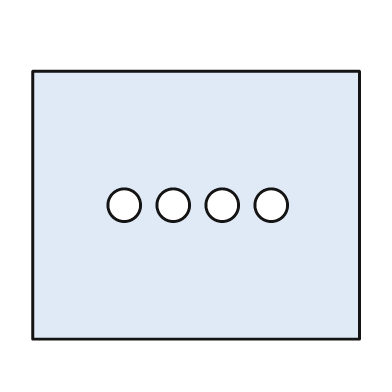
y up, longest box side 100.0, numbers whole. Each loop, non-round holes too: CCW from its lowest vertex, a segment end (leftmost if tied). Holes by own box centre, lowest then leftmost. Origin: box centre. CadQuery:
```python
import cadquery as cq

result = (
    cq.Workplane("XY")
    .moveTo(-50.0, -41.0)
    .lineTo(50.0, -41.0)
    .lineTo(50.0, 41.0)
    .lineTo(-50.0, 41.0)
    .close()
    .moveTo(-22.0, 0.0)
    .circle(5.0)
    .moveTo(-7.0, 0.0)
    .circle(5.0)
    .moveTo(8.0, 0.0)
    .circle(5.0)
    .moveTo(23.0, 0.0)
    .circle(5.0)
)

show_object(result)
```